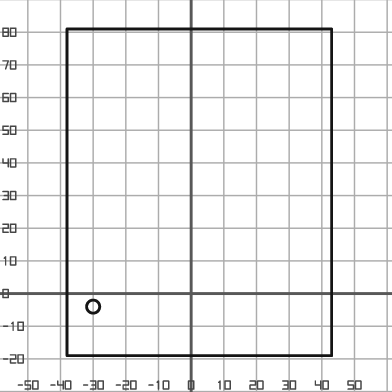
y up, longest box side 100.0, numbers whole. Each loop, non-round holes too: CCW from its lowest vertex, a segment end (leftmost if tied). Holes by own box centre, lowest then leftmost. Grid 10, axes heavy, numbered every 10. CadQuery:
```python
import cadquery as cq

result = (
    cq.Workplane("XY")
    .moveTo(-38.0, -19.0)
    .lineTo(43.0, -19.0)
    .lineTo(43.0, 81.0)
    .lineTo(-38.0, 81.0)
    .close()
    .moveTo(-30.0, -4.0)
    .circle(2.0)
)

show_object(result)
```